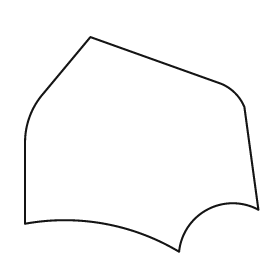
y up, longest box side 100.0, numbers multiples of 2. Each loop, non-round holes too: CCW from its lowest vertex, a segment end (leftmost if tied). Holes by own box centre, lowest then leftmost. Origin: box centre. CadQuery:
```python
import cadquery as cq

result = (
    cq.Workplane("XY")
    .moveTo(16.0, -46.0)
    .threePointArc((28.0, -28.0), (50.0, -28.0))
    .lineTo(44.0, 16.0)
    .threePointArc((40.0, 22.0), (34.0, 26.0))
    .lineTo(-22.0, 46.0)
    .lineTo(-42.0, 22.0)
    .threePointArc((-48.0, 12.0), (-50.0, 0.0))
    .lineTo(-50.0, -34.0)
    .threePointArc((-16.0, -34.0), (16.0, -46.0))
    .close()
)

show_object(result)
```